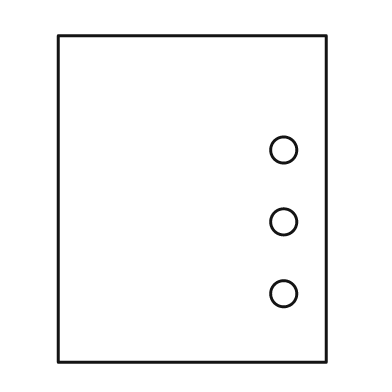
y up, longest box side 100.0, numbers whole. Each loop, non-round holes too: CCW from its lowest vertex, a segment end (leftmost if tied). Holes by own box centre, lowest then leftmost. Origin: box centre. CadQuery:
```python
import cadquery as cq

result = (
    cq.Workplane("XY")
    .moveTo(-41.0, -50.0)
    .lineTo(41.0, -50.0)
    .lineTo(41.0, 50.0)
    .lineTo(-41.0, 50.0)
    .close()
    .moveTo(28.0, -29.0)
    .circle(4.0)
    .moveTo(28.0, -7.0)
    .circle(4.0)
    .moveTo(28.0, 15.0)
    .circle(4.0)
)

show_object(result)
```